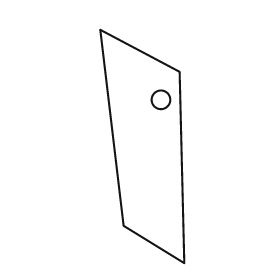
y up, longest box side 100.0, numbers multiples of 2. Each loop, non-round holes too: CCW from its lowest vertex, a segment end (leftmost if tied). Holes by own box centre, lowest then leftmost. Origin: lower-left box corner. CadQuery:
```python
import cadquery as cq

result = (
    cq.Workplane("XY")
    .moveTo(36.0, 0.0)
    .lineTo(34.0, 82.0)
    .lineTo(0.0, 100.0)
    .lineTo(10.0, 16.0)
    .close()
    .moveTo(26.0, 70.0)
    .circle(4.0)
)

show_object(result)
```